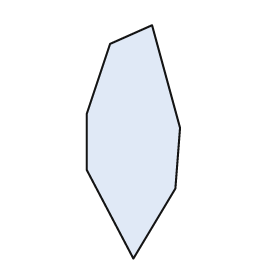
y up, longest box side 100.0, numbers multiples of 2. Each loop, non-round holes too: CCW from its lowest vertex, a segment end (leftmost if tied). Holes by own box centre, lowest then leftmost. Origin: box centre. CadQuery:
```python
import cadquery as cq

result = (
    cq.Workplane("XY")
    .moveTo(0.0, -50.0)
    .lineTo(18.0, -20.0)
    .lineTo(20.0, 6.0)
    .lineTo(8.0, 50.0)
    .lineTo(-10.0, 42.0)
    .lineTo(-20.0, 12.0)
    .lineTo(-20.0, -12.0)
    .close()
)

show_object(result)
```